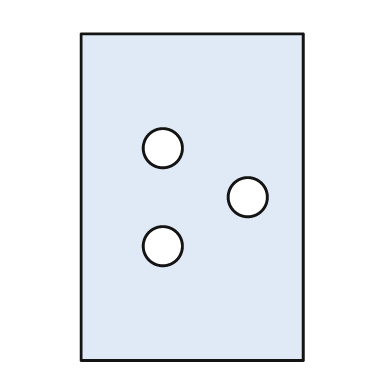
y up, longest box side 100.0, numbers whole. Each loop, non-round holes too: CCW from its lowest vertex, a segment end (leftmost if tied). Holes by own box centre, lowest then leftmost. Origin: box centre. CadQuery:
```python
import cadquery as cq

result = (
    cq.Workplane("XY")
    .moveTo(-34.0, -50.0)
    .lineTo(34.0, -50.0)
    .lineTo(34.0, 50.0)
    .lineTo(-34.0, 50.0)
    .close()
    .moveTo(-9.0, -15.0)
    .circle(6.0)
    .moveTo(17.0, 0.0)
    .circle(6.0)
    .moveTo(-9.0, 15.0)
    .circle(6.0)
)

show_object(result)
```